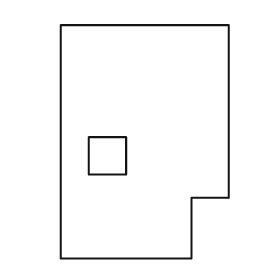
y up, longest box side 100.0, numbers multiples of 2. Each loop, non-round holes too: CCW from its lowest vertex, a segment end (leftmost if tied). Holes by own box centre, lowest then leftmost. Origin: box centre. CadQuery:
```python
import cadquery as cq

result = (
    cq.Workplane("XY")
    .moveTo(-36.0, -50.0)
    .lineTo(20.0, -50.0)
    .lineTo(20.0, -24.0)
    .lineTo(36.0, -24.0)
    .lineTo(36.0, 50.0)
    .lineTo(-36.0, 50.0)
    .close()
    .moveTo(-24.0, -14.0)
    .lineTo(-8.0, -14.0)
    .lineTo(-8.0, 2.0)
    .lineTo(-24.0, 2.0)
    .close()
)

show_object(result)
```